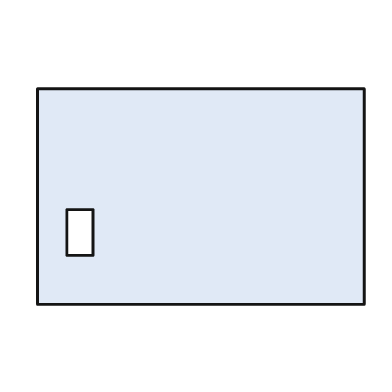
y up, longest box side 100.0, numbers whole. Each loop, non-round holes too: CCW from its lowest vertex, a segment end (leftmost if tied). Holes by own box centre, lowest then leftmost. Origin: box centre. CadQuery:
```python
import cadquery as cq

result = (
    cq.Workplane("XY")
    .moveTo(-50.0, -33.0)
    .lineTo(50.0, -33.0)
    .lineTo(50.0, 33.0)
    .lineTo(-50.0, 33.0)
    .close()
    .moveTo(-41.0, -18.0)
    .lineTo(-33.0, -18.0)
    .lineTo(-33.0, -4.0)
    .lineTo(-41.0, -4.0)
    .close()
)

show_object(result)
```